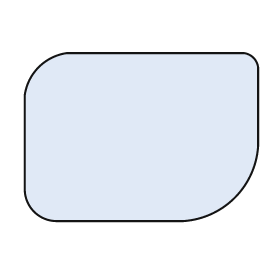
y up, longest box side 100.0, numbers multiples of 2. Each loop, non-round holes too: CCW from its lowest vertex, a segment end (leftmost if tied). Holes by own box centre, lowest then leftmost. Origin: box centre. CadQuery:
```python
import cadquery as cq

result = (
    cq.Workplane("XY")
    .moveTo(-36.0, -36.0)
    .lineTo(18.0, -36.0)
    .threePointArc((40.0, -26.0), (50.0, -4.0))
    .lineTo(50.0, 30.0)
    .threePointArc((48.0, 34.0), (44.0, 36.0))
    .lineTo(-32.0, 36.0)
    .threePointArc((-44.0, 30.0), (-50.0, 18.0))
    .lineTo(-50.0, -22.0)
    .threePointArc((-46.0, -32.0), (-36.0, -36.0))
    .close()
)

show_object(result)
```